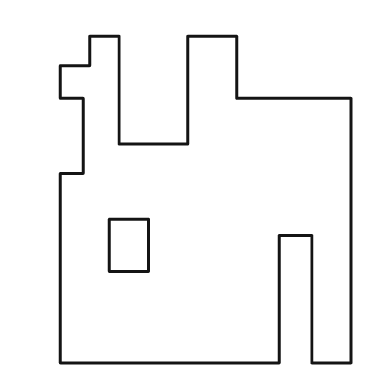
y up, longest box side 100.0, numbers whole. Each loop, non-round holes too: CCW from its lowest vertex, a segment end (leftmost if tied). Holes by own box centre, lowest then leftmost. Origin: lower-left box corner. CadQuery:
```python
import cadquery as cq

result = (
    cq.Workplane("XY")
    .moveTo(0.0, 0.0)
    .lineTo(67.0, 0.0)
    .lineTo(67.0, 39.0)
    .lineTo(77.0, 39.0)
    .lineTo(77.0, 0.0)
    .lineTo(89.0, 0.0)
    .lineTo(89.0, 81.0)
    .lineTo(54.0, 81.0)
    .lineTo(54.0, 100.0)
    .lineTo(39.0, 100.0)
    .lineTo(39.0, 67.0)
    .lineTo(18.0, 67.0)
    .lineTo(18.0, 100.0)
    .lineTo(9.0, 100.0)
    .lineTo(9.0, 91.0)
    .lineTo(0.0, 91.0)
    .lineTo(0.0, 81.0)
    .lineTo(7.0, 81.0)
    .lineTo(7.0, 58.0)
    .lineTo(0.0, 58.0)
    .close()
    .moveTo(15.0, 28.0)
    .lineTo(27.0, 28.0)
    .lineTo(27.0, 44.0)
    .lineTo(15.0, 44.0)
    .close()
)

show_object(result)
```